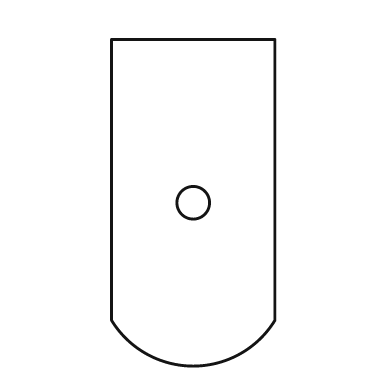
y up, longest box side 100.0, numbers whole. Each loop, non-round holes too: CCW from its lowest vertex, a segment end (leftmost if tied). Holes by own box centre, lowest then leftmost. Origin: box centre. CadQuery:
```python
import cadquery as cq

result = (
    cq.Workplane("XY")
    .moveTo(-25.0, -36.0)
    .threePointArc((0.0, -50.0), (25.0, -36.0))
    .lineTo(25.0, 50.0)
    .lineTo(-25.0, 50.0)
    .close()
    .moveTo(0.0, 0.0)
    .circle(5.0)
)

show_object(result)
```